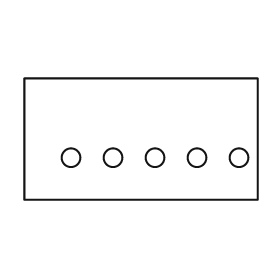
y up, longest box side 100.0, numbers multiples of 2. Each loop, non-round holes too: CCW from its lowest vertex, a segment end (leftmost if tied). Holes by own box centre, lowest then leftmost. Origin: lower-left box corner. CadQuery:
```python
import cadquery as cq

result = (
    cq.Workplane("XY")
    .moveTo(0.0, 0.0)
    .lineTo(100.0, 0.0)
    .lineTo(100.0, 52.0)
    .lineTo(0.0, 52.0)
    .close()
    .moveTo(20.0, 18.0)
    .circle(4.0)
    .moveTo(38.0, 18.0)
    .circle(4.0)
    .moveTo(56.0, 18.0)
    .circle(4.0)
    .moveTo(74.0, 18.0)
    .circle(4.0)
    .moveTo(92.0, 18.0)
    .circle(4.0)
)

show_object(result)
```